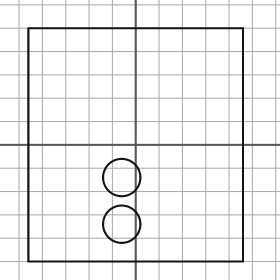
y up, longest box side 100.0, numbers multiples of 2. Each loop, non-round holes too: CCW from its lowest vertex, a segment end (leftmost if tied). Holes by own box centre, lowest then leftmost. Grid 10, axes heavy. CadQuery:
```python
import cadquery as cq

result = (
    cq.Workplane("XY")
    .moveTo(-46.0, -50.0)
    .lineTo(46.0, -50.0)
    .lineTo(46.0, 50.0)
    .lineTo(-46.0, 50.0)
    .close()
    .moveTo(-6.0, -34.0)
    .circle(8.0)
    .moveTo(-6.0, -14.0)
    .circle(8.0)
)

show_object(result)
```